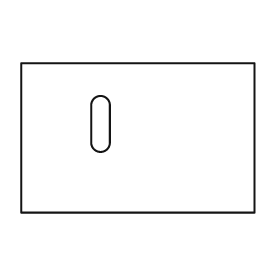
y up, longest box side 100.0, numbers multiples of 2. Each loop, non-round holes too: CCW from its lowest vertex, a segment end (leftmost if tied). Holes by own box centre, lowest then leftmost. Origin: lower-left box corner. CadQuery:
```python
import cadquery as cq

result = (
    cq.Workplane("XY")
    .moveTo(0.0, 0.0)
    .lineTo(100.0, 0.0)
    .lineTo(100.0, 64.0)
    .lineTo(0.0, 64.0)
    .close()
    .moveTo(30.0, 30.0)
    .threePointArc((34.0, 26.0), (38.0, 30.0))
    .lineTo(38.0, 46.0)
    .threePointArc((34.0, 50.0), (30.0, 46.0))
    .close()
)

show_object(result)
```